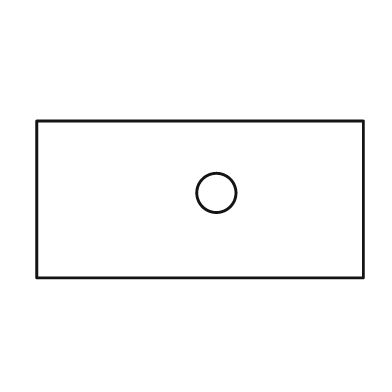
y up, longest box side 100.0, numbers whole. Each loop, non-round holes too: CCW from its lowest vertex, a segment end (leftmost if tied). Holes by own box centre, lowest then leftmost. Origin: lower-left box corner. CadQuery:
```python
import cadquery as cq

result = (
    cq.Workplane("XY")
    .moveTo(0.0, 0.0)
    .lineTo(100.0, 0.0)
    .lineTo(100.0, 48.0)
    .lineTo(0.0, 48.0)
    .close()
    .moveTo(55.0, 26.0)
    .circle(6.0)
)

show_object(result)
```